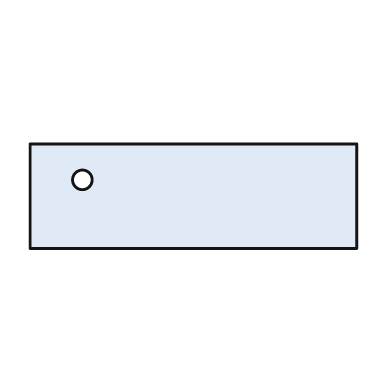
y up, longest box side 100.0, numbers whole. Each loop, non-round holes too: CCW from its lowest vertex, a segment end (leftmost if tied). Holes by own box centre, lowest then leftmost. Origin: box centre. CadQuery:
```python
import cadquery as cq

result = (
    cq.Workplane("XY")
    .moveTo(-50.0, -16.0)
    .lineTo(50.0, -16.0)
    .lineTo(50.0, 16.0)
    .lineTo(-50.0, 16.0)
    .close()
    .moveTo(-34.0, 5.0)
    .circle(3.0)
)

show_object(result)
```